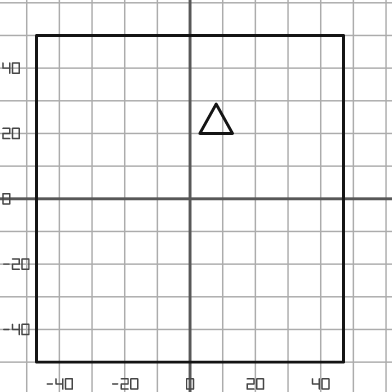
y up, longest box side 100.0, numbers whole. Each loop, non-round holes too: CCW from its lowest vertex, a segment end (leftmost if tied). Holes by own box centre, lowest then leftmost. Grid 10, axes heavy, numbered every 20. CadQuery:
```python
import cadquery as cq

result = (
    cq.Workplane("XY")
    .moveTo(-47.0, -50.0)
    .lineTo(47.0, -50.0)
    .lineTo(47.0, 50.0)
    .lineTo(-47.0, 50.0)
    .close()
    .moveTo(3.0, 20.0)
    .lineTo(13.0, 20.0)
    .lineTo(8.0, 29.0)
    .close()
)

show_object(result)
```